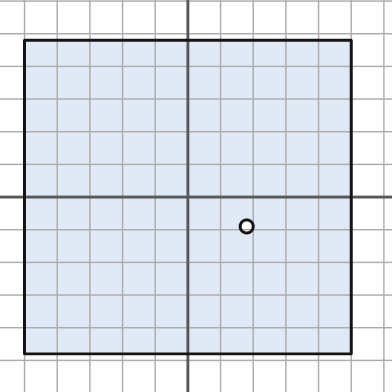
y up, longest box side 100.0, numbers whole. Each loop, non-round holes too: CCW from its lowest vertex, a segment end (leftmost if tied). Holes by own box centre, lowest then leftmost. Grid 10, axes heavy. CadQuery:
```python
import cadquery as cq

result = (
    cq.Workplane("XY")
    .moveTo(-50.0, -48.0)
    .lineTo(50.0, -48.0)
    .lineTo(50.0, 48.0)
    .lineTo(-50.0, 48.0)
    .close()
    .moveTo(18.0, -9.0)
    .circle(2.0)
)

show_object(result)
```